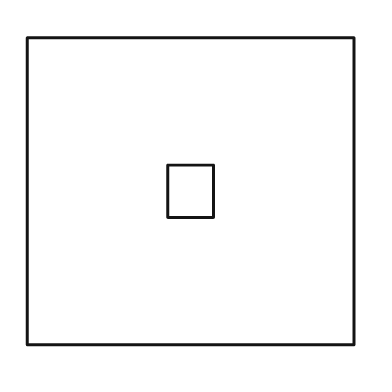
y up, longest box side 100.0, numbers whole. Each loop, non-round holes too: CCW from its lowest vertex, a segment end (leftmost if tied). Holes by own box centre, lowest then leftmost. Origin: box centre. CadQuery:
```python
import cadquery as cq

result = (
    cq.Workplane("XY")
    .moveTo(-50.0, -47.0)
    .lineTo(50.0, -47.0)
    .lineTo(50.0, 47.0)
    .lineTo(-50.0, 47.0)
    .close()
    .moveTo(-7.0, -8.0)
    .lineTo(7.0, -8.0)
    .lineTo(7.0, 8.0)
    .lineTo(-7.0, 8.0)
    .close()
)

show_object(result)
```